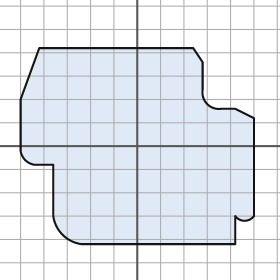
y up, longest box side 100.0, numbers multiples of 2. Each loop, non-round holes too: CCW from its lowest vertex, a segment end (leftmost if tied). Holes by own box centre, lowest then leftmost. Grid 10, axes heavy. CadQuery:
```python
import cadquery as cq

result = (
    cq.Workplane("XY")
    .moveTo(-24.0, -42.0)
    .lineTo(42.0, -42.0)
    .lineTo(42.0, -30.0)
    .threePointArc((46.0, -32.0), (50.0, -30.0))
    .lineTo(50.0, 12.0)
    .lineTo(42.0, 16.0)
    .lineTo(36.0, 16.0)
    .threePointArc((30.0, 18.0), (28.0, 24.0))
    .lineTo(28.0, 36.0)
    .lineTo(24.0, 42.0)
    .lineTo(-42.0, 42.0)
    .lineTo(-50.0, 20.0)
    .lineTo(-50.0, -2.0)
    .threePointArc((-48.0, -6.0), (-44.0, -8.0))
    .lineTo(-36.0, -8.0)
    .lineTo(-36.0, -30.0)
    .threePointArc((-32.0, -38.0), (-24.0, -42.0))
    .close()
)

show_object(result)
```